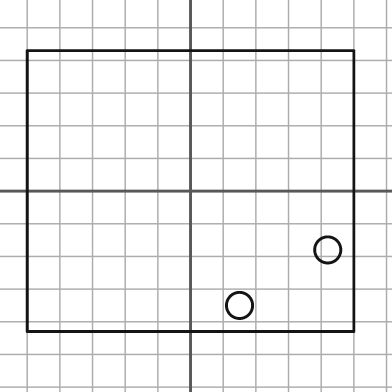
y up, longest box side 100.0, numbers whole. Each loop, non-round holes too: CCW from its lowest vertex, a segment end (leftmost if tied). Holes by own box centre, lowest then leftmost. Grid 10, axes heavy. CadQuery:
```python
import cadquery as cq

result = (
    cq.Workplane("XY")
    .moveTo(-50.0, -43.0)
    .lineTo(50.0, -43.0)
    .lineTo(50.0, 43.0)
    .lineTo(-50.0, 43.0)
    .close()
    .moveTo(15.0, -35.0)
    .circle(4.0)
    .moveTo(42.0, -18.0)
    .circle(4.0)
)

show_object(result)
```